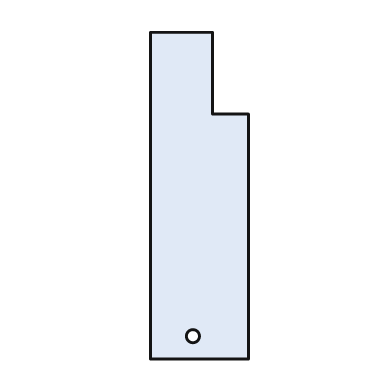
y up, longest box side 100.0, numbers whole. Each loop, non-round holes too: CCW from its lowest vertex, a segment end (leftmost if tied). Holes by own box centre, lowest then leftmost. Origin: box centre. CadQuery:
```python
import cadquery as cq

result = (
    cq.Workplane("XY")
    .moveTo(-15.0, -50.0)
    .lineTo(15.0, -50.0)
    .lineTo(15.0, 25.0)
    .lineTo(4.0, 25.0)
    .lineTo(4.0, 50.0)
    .lineTo(-15.0, 50.0)
    .close()
    .moveTo(-2.0, -43.0)
    .circle(2.0)
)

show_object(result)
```